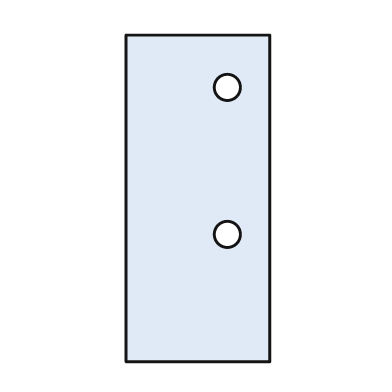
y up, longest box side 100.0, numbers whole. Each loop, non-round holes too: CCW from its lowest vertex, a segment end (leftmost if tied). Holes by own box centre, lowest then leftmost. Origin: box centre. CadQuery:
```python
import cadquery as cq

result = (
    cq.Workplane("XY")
    .moveTo(-22.0, -50.0)
    .lineTo(22.0, -50.0)
    .lineTo(22.0, 50.0)
    .lineTo(-22.0, 50.0)
    .close()
    .moveTo(9.0, -11.0)
    .circle(4.0)
    .moveTo(9.0, 34.0)
    .circle(4.0)
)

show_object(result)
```